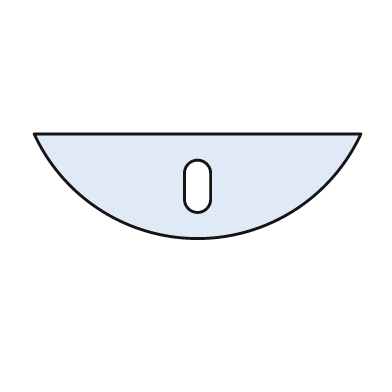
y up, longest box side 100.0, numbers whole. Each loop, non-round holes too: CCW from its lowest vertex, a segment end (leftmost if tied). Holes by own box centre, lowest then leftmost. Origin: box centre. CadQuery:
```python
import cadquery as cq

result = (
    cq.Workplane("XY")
    .moveTo(-50.0, 16.0)
    .threePointArc((0.0, -16.0), (50.0, 16.0))
    .close()
    .moveTo(-4.0, -4.0)
    .threePointArc((0.0, -8.0), (4.0, -4.0))
    .lineTo(4.0, 4.0)
    .threePointArc((0.0, 8.0), (-4.0, 4.0))
    .close()
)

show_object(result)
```